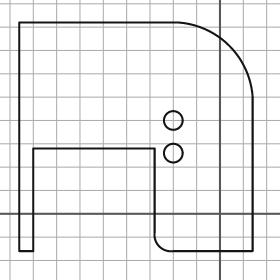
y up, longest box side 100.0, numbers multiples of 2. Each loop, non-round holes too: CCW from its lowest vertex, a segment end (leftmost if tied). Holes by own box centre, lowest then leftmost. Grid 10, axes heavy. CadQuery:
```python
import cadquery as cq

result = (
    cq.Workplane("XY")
    .moveTo(-86.0, -16.0)
    .lineTo(-80.0, -16.0)
    .lineTo(-80.0, 28.0)
    .lineTo(-28.0, 28.0)
    .lineTo(-28.0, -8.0)
    .threePointArc((-26.0, -14.0), (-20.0, -16.0))
    .lineTo(14.0, -16.0)
    .lineTo(14.0, 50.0)
    .threePointArc((4.0, 72.0), (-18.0, 82.0))
    .lineTo(-86.0, 82.0)
    .close()
    .moveTo(-20.0, 26.0)
    .circle(4.0)
    .moveTo(-20.0, 40.0)
    .circle(4.0)
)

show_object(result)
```